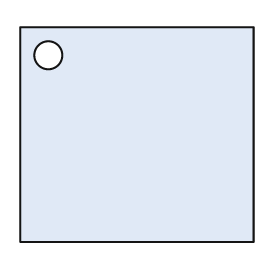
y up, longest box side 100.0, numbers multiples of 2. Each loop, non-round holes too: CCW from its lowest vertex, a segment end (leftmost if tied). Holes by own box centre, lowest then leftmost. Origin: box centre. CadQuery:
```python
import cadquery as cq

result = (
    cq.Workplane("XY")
    .moveTo(-50.0, -46.0)
    .lineTo(50.0, -46.0)
    .lineTo(50.0, 46.0)
    .lineTo(-50.0, 46.0)
    .close()
    .moveTo(-38.0, 34.0)
    .circle(6.0)
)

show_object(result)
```